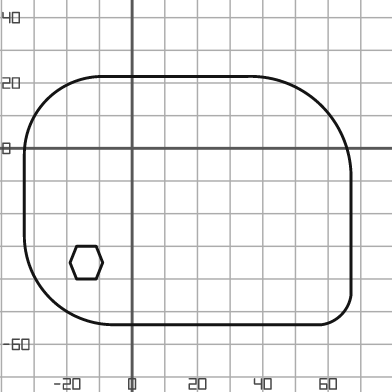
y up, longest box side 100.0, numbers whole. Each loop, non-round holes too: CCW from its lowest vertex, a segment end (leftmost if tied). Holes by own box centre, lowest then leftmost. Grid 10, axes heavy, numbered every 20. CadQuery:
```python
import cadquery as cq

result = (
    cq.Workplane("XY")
    .moveTo(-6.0, -54.0)
    .lineTo(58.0, -54.0)
    .threePointArc((64.0, -51.0), (67.0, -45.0))
    .lineTo(67.0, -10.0)
    .threePointArc((58.0, 13.0), (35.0, 22.0))
    .lineTo(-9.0, 22.0)
    .threePointArc((-26.0, 15.0), (-33.0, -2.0))
    .lineTo(-33.0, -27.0)
    .threePointArc((-25.0, -46.0), (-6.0, -54.0))
    .close()
    .moveTo(-17.0, -40.0)
    .lineTo(-11.0, -40.0)
    .lineTo(-9.0, -35.0)
    .lineTo(-11.0, -30.0)
    .lineTo(-17.0, -30.0)
    .lineTo(-19.0, -35.0)
    .close()
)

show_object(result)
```